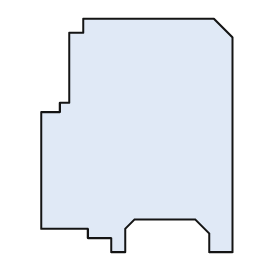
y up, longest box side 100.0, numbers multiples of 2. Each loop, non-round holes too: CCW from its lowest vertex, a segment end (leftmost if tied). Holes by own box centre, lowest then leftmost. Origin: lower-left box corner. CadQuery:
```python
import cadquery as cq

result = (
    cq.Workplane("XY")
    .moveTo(30.0, 0.0)
    .lineTo(36.0, 0.0)
    .lineTo(36.0, 10.0)
    .lineTo(40.0, 14.0)
    .lineTo(66.0, 14.0)
    .lineTo(72.0, 8.0)
    .lineTo(72.0, 0.0)
    .lineTo(82.0, 0.0)
    .lineTo(82.0, 92.0)
    .lineTo(74.0, 100.0)
    .lineTo(18.0, 100.0)
    .lineTo(18.0, 94.0)
    .lineTo(12.0, 94.0)
    .lineTo(12.0, 64.0)
    .lineTo(8.0, 64.0)
    .lineTo(8.0, 60.0)
    .lineTo(0.0, 60.0)
    .lineTo(0.0, 10.0)
    .lineTo(20.0, 10.0)
    .lineTo(20.0, 6.0)
    .lineTo(30.0, 6.0)
    .close()
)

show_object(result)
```